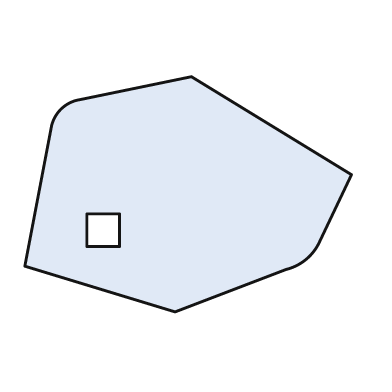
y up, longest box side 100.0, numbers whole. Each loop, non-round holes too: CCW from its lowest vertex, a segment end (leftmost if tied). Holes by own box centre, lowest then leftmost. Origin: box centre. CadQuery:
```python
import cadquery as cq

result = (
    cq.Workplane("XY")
    .moveTo(-4.0, -36.0)
    .lineTo(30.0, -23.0)
    .threePointArc((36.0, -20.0), (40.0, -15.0))
    .lineTo(50.0, 6.0)
    .lineTo(1.0, 36.0)
    .lineTo(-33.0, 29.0)
    .threePointArc((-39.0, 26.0), (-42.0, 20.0))
    .lineTo(-50.0, -22.0)
    .close()
    .moveTo(-31.0, -16.0)
    .lineTo(-21.0, -16.0)
    .lineTo(-21.0, -6.0)
    .lineTo(-31.0, -6.0)
    .close()
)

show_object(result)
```